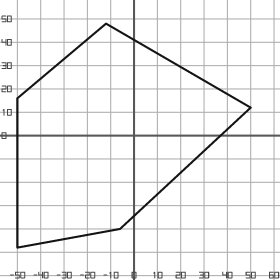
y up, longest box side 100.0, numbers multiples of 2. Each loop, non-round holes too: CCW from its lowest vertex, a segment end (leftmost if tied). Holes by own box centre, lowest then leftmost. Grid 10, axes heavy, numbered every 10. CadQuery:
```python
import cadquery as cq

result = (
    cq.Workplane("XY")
    .moveTo(-50.0, -48.0)
    .lineTo(-6.0, -40.0)
    .lineTo(50.0, 12.0)
    .lineTo(-12.0, 48.0)
    .lineTo(-50.0, 16.0)
    .close()
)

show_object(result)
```